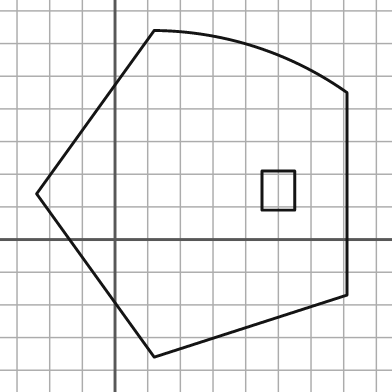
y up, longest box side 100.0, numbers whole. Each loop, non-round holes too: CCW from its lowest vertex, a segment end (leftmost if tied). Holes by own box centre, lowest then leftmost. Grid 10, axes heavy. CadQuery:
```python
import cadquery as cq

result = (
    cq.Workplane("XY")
    .moveTo(12.0, -36.0)
    .lineTo(71.0, -17.0)
    .lineTo(71.0, 45.0)
    .threePointArc((43.0, 59.0), (12.0, 64.0))
    .lineTo(-24.0, 14.0)
    .close()
    .moveTo(45.0, 9.0)
    .lineTo(55.0, 9.0)
    .lineTo(55.0, 21.0)
    .lineTo(45.0, 21.0)
    .close()
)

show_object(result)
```